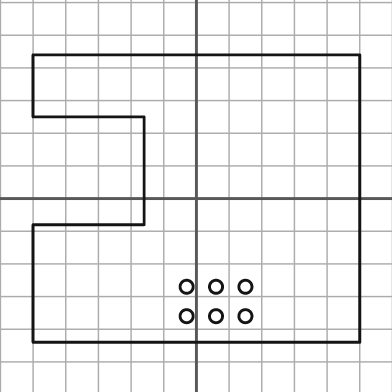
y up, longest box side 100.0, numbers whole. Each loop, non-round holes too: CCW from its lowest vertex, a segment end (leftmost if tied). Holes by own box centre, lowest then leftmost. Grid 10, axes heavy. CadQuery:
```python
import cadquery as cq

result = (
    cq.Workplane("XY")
    .moveTo(-50.0, -44.0)
    .lineTo(50.0, -44.0)
    .lineTo(50.0, 44.0)
    .lineTo(-50.0, 44.0)
    .lineTo(-50.0, 25.0)
    .lineTo(-16.0, 25.0)
    .lineTo(-16.0, -8.0)
    .lineTo(-50.0, -8.0)
    .close()
    .moveTo(-3.0, -36.0)
    .circle(2.0)
    .moveTo(6.0, -36.0)
    .circle(2.0)
    .moveTo(15.0, -36.0)
    .circle(2.0)
    .moveTo(-3.0, -27.0)
    .circle(2.0)
    .moveTo(6.0, -27.0)
    .circle(2.0)
    .moveTo(15.0, -27.0)
    .circle(2.0)
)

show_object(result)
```